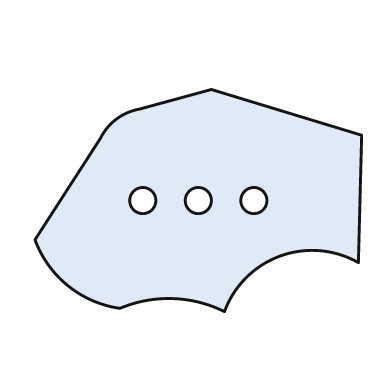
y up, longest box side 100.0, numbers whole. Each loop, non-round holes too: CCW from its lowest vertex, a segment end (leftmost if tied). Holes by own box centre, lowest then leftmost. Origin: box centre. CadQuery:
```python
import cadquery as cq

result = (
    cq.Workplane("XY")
    .moveTo(8.0, -34.0)
    .threePointArc((25.0, -17.0), (49.0, -19.0))
    .lineTo(50.0, 20.0)
    .lineTo(4.0, 34.0)
    .lineTo(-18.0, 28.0)
    .threePointArc((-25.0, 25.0), (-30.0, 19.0))
    .lineTo(-50.0, -12.0)
    .threePointArc((-40.0, -26.0), (-24.0, -33.0))
    .threePointArc((-8.0, -30.0), (8.0, -34.0))
    .close()
    .moveTo(-17.0, 0.0)
    .circle(4.0)
    .moveTo(0.0, 0.0)
    .circle(4.0)
    .moveTo(17.0, 0.0)
    .circle(4.0)
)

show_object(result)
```